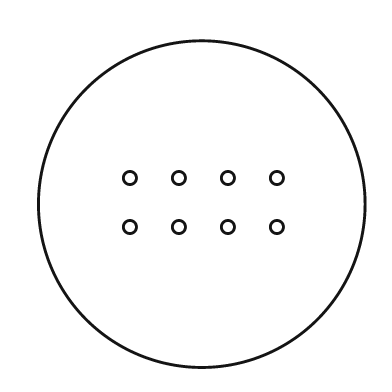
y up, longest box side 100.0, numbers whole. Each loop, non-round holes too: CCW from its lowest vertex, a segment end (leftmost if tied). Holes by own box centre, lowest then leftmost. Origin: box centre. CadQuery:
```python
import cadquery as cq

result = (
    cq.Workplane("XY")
    .moveTo(0.0, 0.0)
    .circle(50.0)
    .moveTo(-22.0, -7.0)
    .circle(2.0)
    .moveTo(-7.0, -7.0)
    .circle(2.0)
    .moveTo(8.0, -7.0)
    .circle(2.0)
    .moveTo(23.0, -7.0)
    .circle(2.0)
    .moveTo(-22.0, 8.0)
    .circle(2.0)
    .moveTo(-7.0, 8.0)
    .circle(2.0)
    .moveTo(8.0, 8.0)
    .circle(2.0)
    .moveTo(23.0, 8.0)
    .circle(2.0)
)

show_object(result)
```